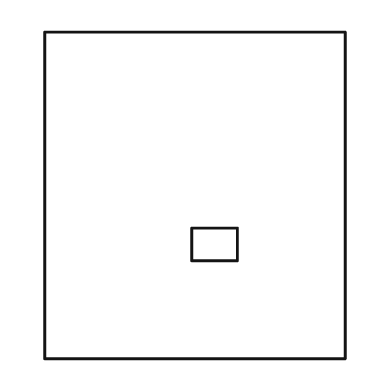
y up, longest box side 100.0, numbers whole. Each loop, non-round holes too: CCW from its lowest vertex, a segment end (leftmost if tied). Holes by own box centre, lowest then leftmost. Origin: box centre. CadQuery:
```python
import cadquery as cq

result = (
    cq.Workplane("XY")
    .moveTo(-46.0, -50.0)
    .lineTo(46.0, -50.0)
    .lineTo(46.0, 50.0)
    .lineTo(-46.0, 50.0)
    .close()
    .moveTo(-1.0, -20.0)
    .lineTo(13.0, -20.0)
    .lineTo(13.0, -10.0)
    .lineTo(-1.0, -10.0)
    .close()
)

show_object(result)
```